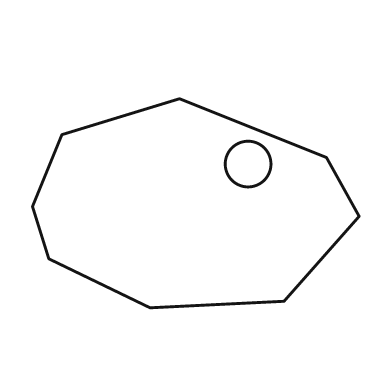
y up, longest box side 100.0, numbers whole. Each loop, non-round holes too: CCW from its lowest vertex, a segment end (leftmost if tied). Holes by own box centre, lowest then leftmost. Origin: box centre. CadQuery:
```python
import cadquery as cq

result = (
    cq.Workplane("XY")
    .moveTo(-14.0, -32.0)
    .lineTo(27.0, -30.0)
    .lineTo(50.0, -4.0)
    .lineTo(40.0, 14.0)
    .lineTo(-5.0, 32.0)
    .lineTo(-41.0, 21.0)
    .lineTo(-50.0, -1.0)
    .lineTo(-45.0, -17.0)
    .close()
    .moveTo(16.0, 12.0)
    .circle(7.0)
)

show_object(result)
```